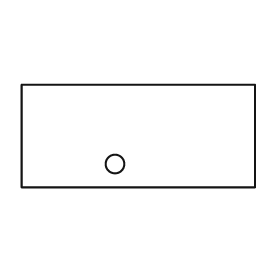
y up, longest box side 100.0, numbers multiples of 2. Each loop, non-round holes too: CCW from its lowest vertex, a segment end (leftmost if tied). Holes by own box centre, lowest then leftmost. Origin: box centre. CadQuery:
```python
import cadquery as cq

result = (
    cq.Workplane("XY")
    .moveTo(-50.0, -22.0)
    .lineTo(50.0, -22.0)
    .lineTo(50.0, 22.0)
    .lineTo(-50.0, 22.0)
    .close()
    .moveTo(-10.0, -12.0)
    .circle(4.0)
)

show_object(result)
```